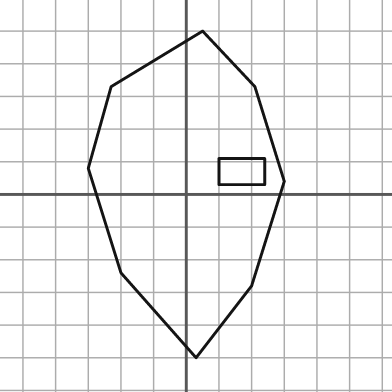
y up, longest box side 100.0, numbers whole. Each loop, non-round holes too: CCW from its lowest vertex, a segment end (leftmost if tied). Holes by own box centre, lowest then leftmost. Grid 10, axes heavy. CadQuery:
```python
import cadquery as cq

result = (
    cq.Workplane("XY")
    .moveTo(3.0, -50.0)
    .lineTo(20.0, -28.0)
    .lineTo(30.0, 4.0)
    .lineTo(21.0, 33.0)
    .lineTo(5.0, 50.0)
    .lineTo(-23.0, 33.0)
    .lineTo(-30.0, 8.0)
    .lineTo(-20.0, -24.0)
    .close()
    .moveTo(10.0, 3.0)
    .lineTo(24.0, 3.0)
    .lineTo(24.0, 11.0)
    .lineTo(10.0, 11.0)
    .close()
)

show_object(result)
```